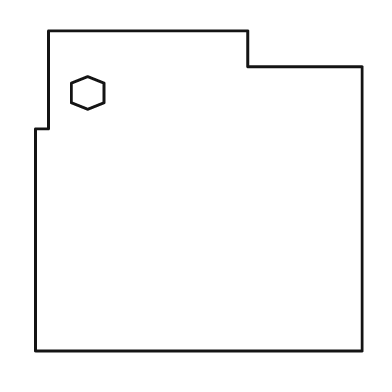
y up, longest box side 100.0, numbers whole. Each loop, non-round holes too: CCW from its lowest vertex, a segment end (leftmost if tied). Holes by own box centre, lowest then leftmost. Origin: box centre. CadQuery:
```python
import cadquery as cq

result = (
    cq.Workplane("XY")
    .moveTo(-50.0, -49.0)
    .lineTo(50.0, -49.0)
    .lineTo(50.0, 38.0)
    .lineTo(15.0, 38.0)
    .lineTo(15.0, 49.0)
    .lineTo(-46.0, 49.0)
    .lineTo(-46.0, 19.0)
    .lineTo(-50.0, 19.0)
    .close()
    .moveTo(-34.0, 25.0)
    .lineTo(-29.0, 27.0)
    .lineTo(-29.0, 33.0)
    .lineTo(-34.0, 35.0)
    .lineTo(-39.0, 33.0)
    .lineTo(-39.0, 27.0)
    .close()
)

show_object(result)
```